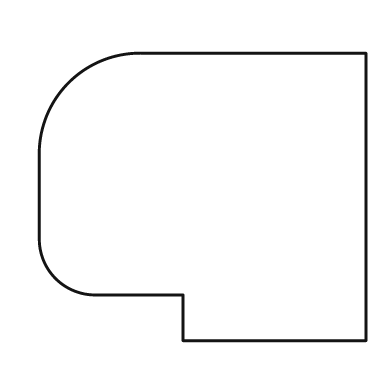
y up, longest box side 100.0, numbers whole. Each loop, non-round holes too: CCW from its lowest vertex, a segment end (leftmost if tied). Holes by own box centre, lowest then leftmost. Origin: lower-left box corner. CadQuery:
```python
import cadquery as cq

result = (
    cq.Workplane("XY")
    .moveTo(44.0, 0.0)
    .lineTo(100.0, 0.0)
    .lineTo(100.0, 88.0)
    .lineTo(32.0, 88.0)
    .threePointArc((9.0, 79.0), (0.0, 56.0))
    .lineTo(0.0, 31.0)
    .threePointArc((5.0, 19.0), (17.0, 14.0))
    .lineTo(44.0, 14.0)
    .close()
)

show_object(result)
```